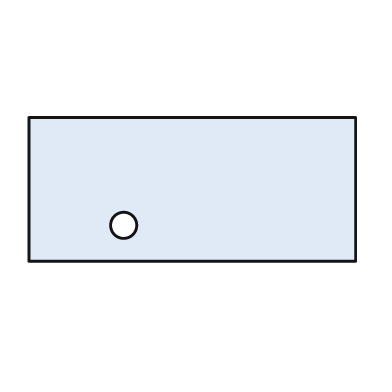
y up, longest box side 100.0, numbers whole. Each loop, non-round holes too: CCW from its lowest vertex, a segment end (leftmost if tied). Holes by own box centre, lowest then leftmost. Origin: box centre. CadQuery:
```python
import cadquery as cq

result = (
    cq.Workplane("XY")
    .moveTo(-50.0, -22.0)
    .lineTo(50.0, -22.0)
    .lineTo(50.0, 22.0)
    .lineTo(-50.0, 22.0)
    .close()
    .moveTo(-21.0, -11.0)
    .circle(4.0)
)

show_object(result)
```